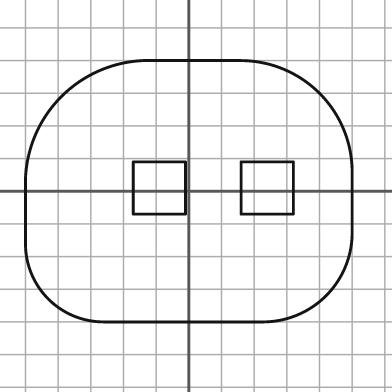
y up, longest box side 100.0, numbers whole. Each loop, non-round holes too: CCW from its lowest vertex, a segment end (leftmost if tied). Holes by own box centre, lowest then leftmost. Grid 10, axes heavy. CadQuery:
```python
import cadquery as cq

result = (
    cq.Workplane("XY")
    .moveTo(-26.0, -40.0)
    .lineTo(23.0, -40.0)
    .threePointArc((42.0, -32.0), (50.0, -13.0))
    .lineTo(50.0, 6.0)
    .threePointArc((40.0, 30.0), (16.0, 40.0))
    .lineTo(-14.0, 40.0)
    .threePointArc((-39.0, 29.0), (-50.0, 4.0))
    .lineTo(-50.0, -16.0)
    .threePointArc((-43.0, -33.0), (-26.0, -40.0))
    .close()
    .moveTo(-17.0, -7.0)
    .lineTo(-1.0, -7.0)
    .lineTo(-1.0, 9.0)
    .lineTo(-17.0, 9.0)
    .close()
    .moveTo(16.0, -7.0)
    .lineTo(32.0, -7.0)
    .lineTo(32.0, 9.0)
    .lineTo(16.0, 9.0)
    .close()
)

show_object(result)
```